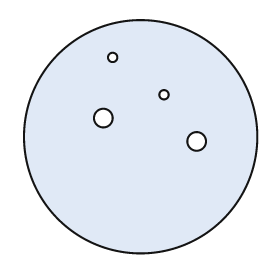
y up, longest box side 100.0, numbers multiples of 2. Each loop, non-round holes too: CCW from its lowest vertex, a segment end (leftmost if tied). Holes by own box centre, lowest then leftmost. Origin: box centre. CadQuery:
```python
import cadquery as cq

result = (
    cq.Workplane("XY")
    .moveTo(0.0, 0.0)
    .circle(50.0)
    .moveTo(24.0, -2.0)
    .circle(4.0)
    .moveTo(-16.0, 8.0)
    .circle(4.0)
    .moveTo(10.0, 18.0)
    .circle(2.0)
    .moveTo(-12.0, 34.0)
    .circle(2.0)
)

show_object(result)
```